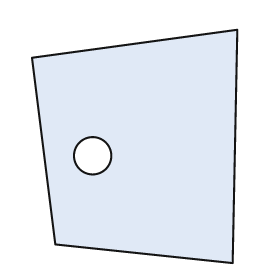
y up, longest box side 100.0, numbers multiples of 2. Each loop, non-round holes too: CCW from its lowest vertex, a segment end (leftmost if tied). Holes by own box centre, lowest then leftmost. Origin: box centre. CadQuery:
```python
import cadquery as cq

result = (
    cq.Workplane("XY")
    .moveTo(42.0, -50.0)
    .lineTo(44.0, 50.0)
    .lineTo(-44.0, 38.0)
    .lineTo(-34.0, -42.0)
    .close()
    .moveTo(-18.0, -4.0)
    .circle(8.0)
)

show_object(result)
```